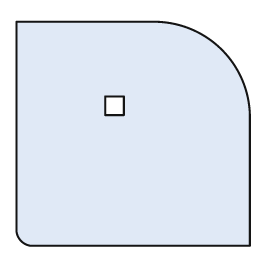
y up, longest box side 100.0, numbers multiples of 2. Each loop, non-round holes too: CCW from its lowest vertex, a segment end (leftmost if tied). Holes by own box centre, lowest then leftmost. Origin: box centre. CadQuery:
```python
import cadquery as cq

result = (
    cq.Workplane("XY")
    .moveTo(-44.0, -48.0)
    .lineTo(50.0, -48.0)
    .lineTo(50.0, 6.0)
    .threePointArc((38.0, 36.0), (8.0, 48.0))
    .lineTo(-50.0, 48.0)
    .lineTo(-50.0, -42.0)
    .threePointArc((-48.0, -46.0), (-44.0, -48.0))
    .close()
    .moveTo(-12.0, 8.0)
    .lineTo(-4.0, 8.0)
    .lineTo(-4.0, 16.0)
    .lineTo(-12.0, 16.0)
    .close()
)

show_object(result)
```